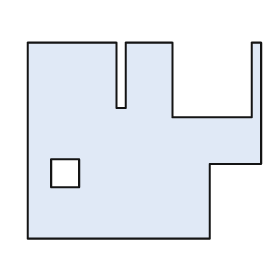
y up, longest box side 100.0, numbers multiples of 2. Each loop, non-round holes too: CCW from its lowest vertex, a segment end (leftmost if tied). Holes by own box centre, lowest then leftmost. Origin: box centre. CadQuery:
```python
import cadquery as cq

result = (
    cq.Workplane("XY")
    .moveTo(-50.0, -42.0)
    .lineTo(28.0, -42.0)
    .lineTo(28.0, -10.0)
    .lineTo(50.0, -10.0)
    .lineTo(50.0, 42.0)
    .lineTo(46.0, 42.0)
    .lineTo(46.0, 10.0)
    .lineTo(12.0, 10.0)
    .lineTo(12.0, 42.0)
    .lineTo(-8.0, 42.0)
    .lineTo(-8.0, 14.0)
    .lineTo(-12.0, 14.0)
    .lineTo(-12.0, 42.0)
    .lineTo(-50.0, 42.0)
    .close()
    .moveTo(-40.0, -20.0)
    .lineTo(-28.0, -20.0)
    .lineTo(-28.0, -8.0)
    .lineTo(-40.0, -8.0)
    .close()
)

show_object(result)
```